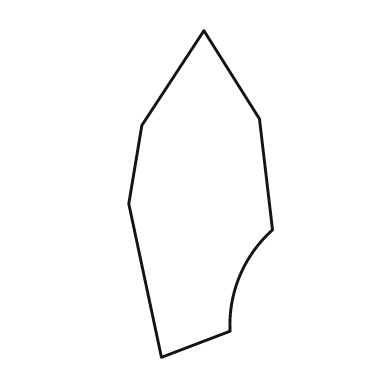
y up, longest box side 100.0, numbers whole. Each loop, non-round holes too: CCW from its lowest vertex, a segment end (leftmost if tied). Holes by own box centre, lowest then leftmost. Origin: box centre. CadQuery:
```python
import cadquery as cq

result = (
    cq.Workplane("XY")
    .moveTo(-12.0, -50.0)
    .lineTo(9.0, -42.0)
    .threePointArc((12.0, -25.0), (22.0, -11.0))
    .lineTo(18.0, 23.0)
    .lineTo(1.0, 50.0)
    .lineTo(-18.0, 21.0)
    .lineTo(-22.0, -3.0)
    .close()
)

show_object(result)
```